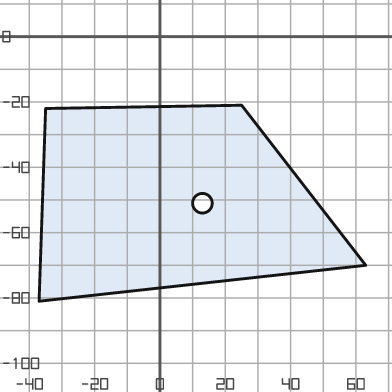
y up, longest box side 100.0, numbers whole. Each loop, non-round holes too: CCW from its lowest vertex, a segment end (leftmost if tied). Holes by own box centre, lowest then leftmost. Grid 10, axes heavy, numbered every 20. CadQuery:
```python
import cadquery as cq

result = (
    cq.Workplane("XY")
    .moveTo(-37.0, -81.0)
    .lineTo(63.0, -70.0)
    .lineTo(25.0, -21.0)
    .lineTo(-35.0, -22.0)
    .close()
    .moveTo(13.0, -51.0)
    .circle(3.0)
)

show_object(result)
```